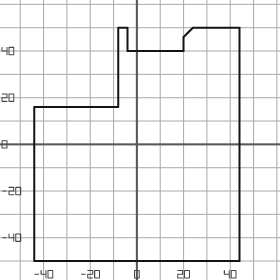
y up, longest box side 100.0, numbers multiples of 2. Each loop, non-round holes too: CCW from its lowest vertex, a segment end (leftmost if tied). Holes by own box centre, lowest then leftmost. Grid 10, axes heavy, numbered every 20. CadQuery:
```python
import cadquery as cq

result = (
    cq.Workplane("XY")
    .moveTo(-44.0, -50.0)
    .lineTo(44.0, -50.0)
    .lineTo(44.0, 50.0)
    .lineTo(24.0, 50.0)
    .lineTo(20.0, 46.0)
    .lineTo(20.0, 40.0)
    .lineTo(-4.0, 40.0)
    .lineTo(-4.0, 50.0)
    .lineTo(-8.0, 50.0)
    .lineTo(-8.0, 16.0)
    .lineTo(-44.0, 16.0)
    .close()
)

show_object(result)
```